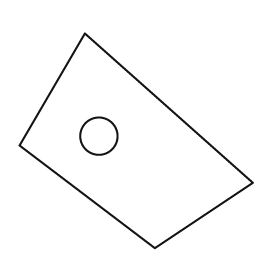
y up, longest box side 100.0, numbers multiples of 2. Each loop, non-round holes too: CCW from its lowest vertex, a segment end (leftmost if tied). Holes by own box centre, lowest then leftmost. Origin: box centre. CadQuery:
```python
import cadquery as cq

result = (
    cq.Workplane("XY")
    .moveTo(8.0, -46.0)
    .lineTo(50.0, -18.0)
    .lineTo(-22.0, 46.0)
    .lineTo(-50.0, -2.0)
    .close()
    .moveTo(-16.0, 2.0)
    .circle(8.0)
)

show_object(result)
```